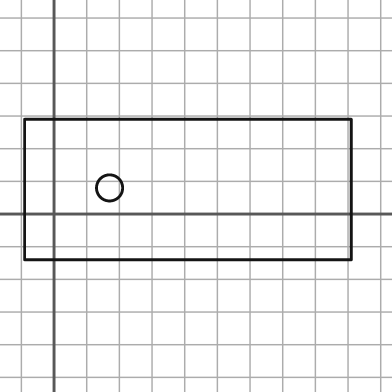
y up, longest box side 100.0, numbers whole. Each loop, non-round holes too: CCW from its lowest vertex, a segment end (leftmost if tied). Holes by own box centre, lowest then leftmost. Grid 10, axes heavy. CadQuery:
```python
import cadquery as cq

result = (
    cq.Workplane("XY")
    .moveTo(-9.0, -14.0)
    .lineTo(91.0, -14.0)
    .lineTo(91.0, 29.0)
    .lineTo(-9.0, 29.0)
    .close()
    .moveTo(17.0, 8.0)
    .circle(4.0)
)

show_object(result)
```